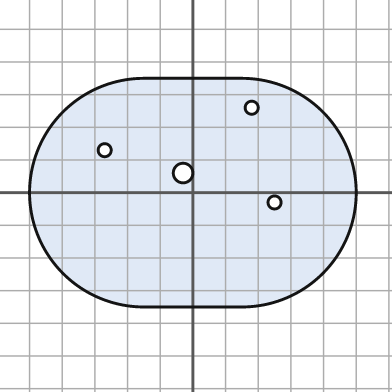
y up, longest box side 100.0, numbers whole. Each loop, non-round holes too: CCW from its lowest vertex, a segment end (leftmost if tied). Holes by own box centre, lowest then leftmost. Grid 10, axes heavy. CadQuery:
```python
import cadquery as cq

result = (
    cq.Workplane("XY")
    .moveTo(-15.0, -35.0)
    .lineTo(15.0, -35.0)
    .threePointArc((50.0, 0.0), (15.0, 35.0))
    .lineTo(-15.0, 35.0)
    .threePointArc((-50.0, 0.0), (-15.0, -35.0))
    .close()
    .moveTo(25.0, -3.0)
    .circle(2.0)
    .moveTo(-3.0, 6.0)
    .circle(3.0)
    .moveTo(-27.0, 13.0)
    .circle(2.0)
    .moveTo(18.0, 26.0)
    .circle(2.0)
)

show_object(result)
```